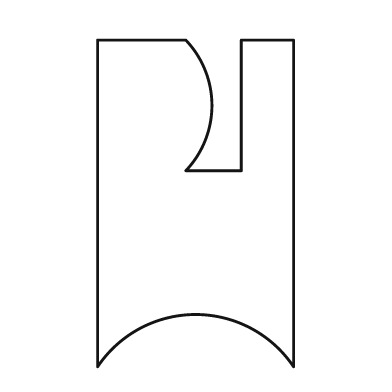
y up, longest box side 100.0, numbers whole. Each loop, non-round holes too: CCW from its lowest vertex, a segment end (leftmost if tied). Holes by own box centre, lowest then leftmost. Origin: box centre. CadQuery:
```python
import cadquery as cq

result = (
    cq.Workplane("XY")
    .moveTo(-30.0, -50.0)
    .threePointArc((0.0, -34.0), (30.0, -50.0))
    .lineTo(30.0, 50.0)
    .lineTo(14.0, 50.0)
    .lineTo(14.0, 10.0)
    .lineTo(-3.0, 10.0)
    .threePointArc((5.0, 30.0), (-3.0, 50.0))
    .lineTo(-30.0, 50.0)
    .close()
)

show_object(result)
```